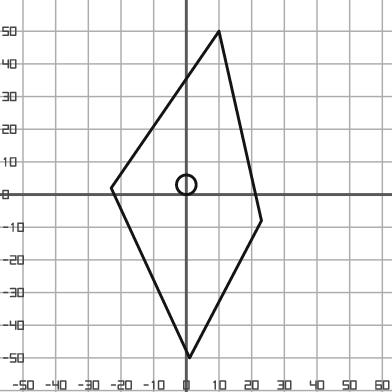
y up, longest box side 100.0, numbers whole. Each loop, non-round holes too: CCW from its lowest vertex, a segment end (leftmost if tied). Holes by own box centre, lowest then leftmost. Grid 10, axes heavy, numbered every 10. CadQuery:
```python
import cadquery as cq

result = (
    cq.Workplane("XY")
    .moveTo(1.0, -50.0)
    .lineTo(23.0, -8.0)
    .lineTo(10.0, 50.0)
    .lineTo(-23.0, 2.0)
    .close()
    .moveTo(0.0, 3.0)
    .circle(3.0)
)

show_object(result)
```